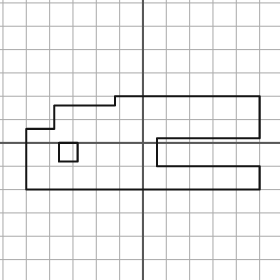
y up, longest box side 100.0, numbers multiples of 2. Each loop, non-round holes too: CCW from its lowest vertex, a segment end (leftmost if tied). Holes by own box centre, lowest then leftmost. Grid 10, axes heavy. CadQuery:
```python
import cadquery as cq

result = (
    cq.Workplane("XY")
    .moveTo(-50.0, -20.0)
    .lineTo(50.0, -20.0)
    .lineTo(50.0, -10.0)
    .lineTo(6.0, -10.0)
    .lineTo(6.0, 2.0)
    .lineTo(50.0, 2.0)
    .lineTo(50.0, 20.0)
    .lineTo(-12.0, 20.0)
    .lineTo(-12.0, 16.0)
    .lineTo(-38.0, 16.0)
    .lineTo(-38.0, 6.0)
    .lineTo(-50.0, 6.0)
    .close()
    .moveTo(-36.0, -8.0)
    .lineTo(-28.0, -8.0)
    .lineTo(-28.0, 0.0)
    .lineTo(-36.0, 0.0)
    .close()
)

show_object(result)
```